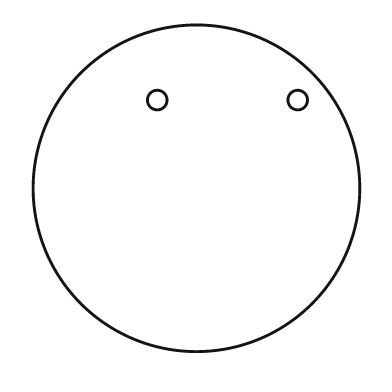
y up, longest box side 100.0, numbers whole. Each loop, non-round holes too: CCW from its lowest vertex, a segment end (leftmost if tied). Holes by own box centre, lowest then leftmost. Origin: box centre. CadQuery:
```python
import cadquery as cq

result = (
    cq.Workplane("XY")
    .moveTo(0.0, 0.0)
    .circle(50.0)
    .moveTo(-12.0, 27.0)
    .circle(3.0)
    .moveTo(31.0, 27.0)
    .circle(3.0)
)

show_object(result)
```